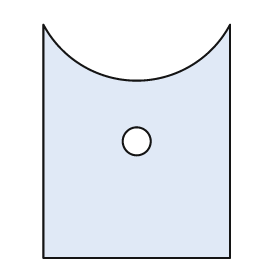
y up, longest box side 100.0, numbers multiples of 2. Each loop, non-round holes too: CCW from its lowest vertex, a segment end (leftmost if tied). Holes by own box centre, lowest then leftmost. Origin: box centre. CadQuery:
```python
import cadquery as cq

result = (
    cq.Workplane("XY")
    .moveTo(-40.0, -50.0)
    .lineTo(40.0, -50.0)
    .lineTo(40.0, 50.0)
    .threePointArc((0.0, 26.0), (-40.0, 50.0))
    .close()
    .moveTo(0.0, 0.0)
    .circle(6.0)
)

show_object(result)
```